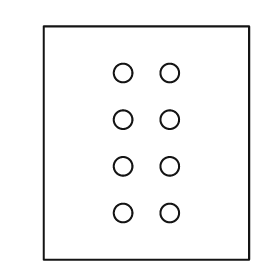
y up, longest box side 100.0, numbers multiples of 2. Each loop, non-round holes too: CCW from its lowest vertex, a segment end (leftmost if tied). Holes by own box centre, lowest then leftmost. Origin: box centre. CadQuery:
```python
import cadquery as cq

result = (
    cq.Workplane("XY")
    .moveTo(-44.0, -50.0)
    .lineTo(44.0, -50.0)
    .lineTo(44.0, 50.0)
    .lineTo(-44.0, 50.0)
    .close()
    .moveTo(-10.0, -30.0)
    .circle(4.0)
    .moveTo(10.0, -30.0)
    .circle(4.0)
    .moveTo(-10.0, -10.0)
    .circle(4.0)
    .moveTo(10.0, -10.0)
    .circle(4.0)
    .moveTo(-10.0, 10.0)
    .circle(4.0)
    .moveTo(10.0, 10.0)
    .circle(4.0)
    .moveTo(-10.0, 30.0)
    .circle(4.0)
    .moveTo(10.0, 30.0)
    .circle(4.0)
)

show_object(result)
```